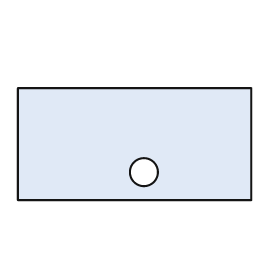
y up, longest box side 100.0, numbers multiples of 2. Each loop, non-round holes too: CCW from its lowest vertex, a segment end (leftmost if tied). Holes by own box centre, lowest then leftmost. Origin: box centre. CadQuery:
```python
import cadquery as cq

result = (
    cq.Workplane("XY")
    .moveTo(-50.0, -24.0)
    .lineTo(50.0, -24.0)
    .lineTo(50.0, 24.0)
    .lineTo(-50.0, 24.0)
    .close()
    .moveTo(4.0, -12.0)
    .circle(6.0)
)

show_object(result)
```